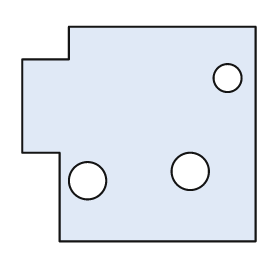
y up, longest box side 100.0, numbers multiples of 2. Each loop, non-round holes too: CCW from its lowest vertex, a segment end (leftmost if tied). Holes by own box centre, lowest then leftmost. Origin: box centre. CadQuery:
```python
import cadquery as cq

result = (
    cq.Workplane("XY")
    .moveTo(-34.0, -46.0)
    .lineTo(50.0, -46.0)
    .lineTo(50.0, 46.0)
    .lineTo(-30.0, 46.0)
    .lineTo(-30.0, 32.0)
    .lineTo(-50.0, 32.0)
    .lineTo(-50.0, -8.0)
    .lineTo(-34.0, -8.0)
    .close()
    .moveTo(-22.0, -20.0)
    .circle(8.0)
    .moveTo(22.0, -16.0)
    .circle(8.0)
    .moveTo(38.0, 24.0)
    .circle(6.0)
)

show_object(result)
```